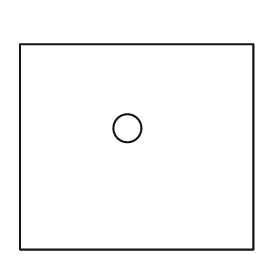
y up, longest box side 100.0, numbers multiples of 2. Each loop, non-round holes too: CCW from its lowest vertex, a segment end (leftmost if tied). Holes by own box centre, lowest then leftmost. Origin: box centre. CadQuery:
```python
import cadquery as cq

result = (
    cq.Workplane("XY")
    .moveTo(-50.0, -44.0)
    .lineTo(50.0, -44.0)
    .lineTo(50.0, 44.0)
    .lineTo(-50.0, 44.0)
    .close()
    .moveTo(-4.0, 8.0)
    .circle(6.0)
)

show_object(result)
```